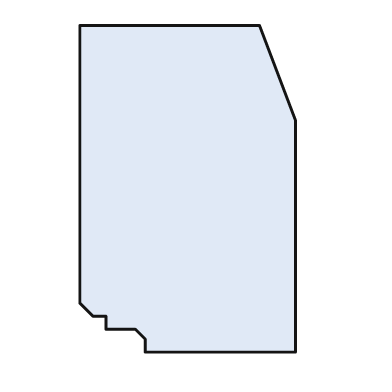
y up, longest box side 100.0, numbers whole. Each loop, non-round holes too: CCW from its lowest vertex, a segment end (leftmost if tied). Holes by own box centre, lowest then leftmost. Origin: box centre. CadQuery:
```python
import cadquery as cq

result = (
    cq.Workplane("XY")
    .moveTo(-13.0, -50.0)
    .lineTo(33.0, -50.0)
    .lineTo(33.0, 21.0)
    .lineTo(22.0, 50.0)
    .lineTo(-33.0, 50.0)
    .lineTo(-33.0, -35.0)
    .lineTo(-29.0, -39.0)
    .lineTo(-25.0, -39.0)
    .lineTo(-25.0, -43.0)
    .lineTo(-16.0, -43.0)
    .lineTo(-13.0, -46.0)
    .close()
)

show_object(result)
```